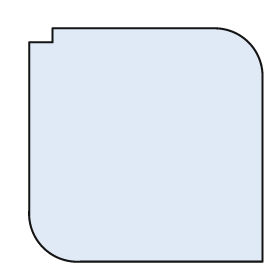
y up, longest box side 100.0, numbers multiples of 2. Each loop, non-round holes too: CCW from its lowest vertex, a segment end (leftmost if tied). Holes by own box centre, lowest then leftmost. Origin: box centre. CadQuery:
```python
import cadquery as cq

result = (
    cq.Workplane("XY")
    .moveTo(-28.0, -50.0)
    .lineTo(50.0, -50.0)
    .lineTo(50.0, 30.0)
    .threePointArc((44.0, 44.0), (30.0, 50.0))
    .lineTo(-40.0, 50.0)
    .lineTo(-40.0, 44.0)
    .lineTo(-50.0, 44.0)
    .lineTo(-50.0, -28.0)
    .threePointArc((-44.0, -44.0), (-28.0, -50.0))
    .close()
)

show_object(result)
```